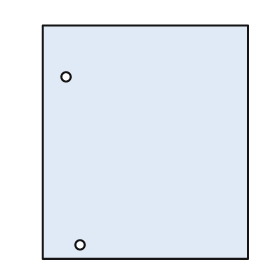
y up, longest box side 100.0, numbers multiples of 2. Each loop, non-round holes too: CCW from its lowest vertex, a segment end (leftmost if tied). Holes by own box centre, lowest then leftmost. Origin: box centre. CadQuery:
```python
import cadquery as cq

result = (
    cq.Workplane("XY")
    .moveTo(-44.0, -50.0)
    .lineTo(44.0, -50.0)
    .lineTo(44.0, 50.0)
    .lineTo(-44.0, 50.0)
    .close()
    .moveTo(-28.0, -44.0)
    .circle(2.0)
    .moveTo(-34.0, 28.0)
    .circle(2.0)
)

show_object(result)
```